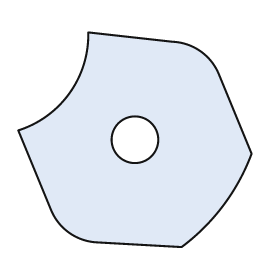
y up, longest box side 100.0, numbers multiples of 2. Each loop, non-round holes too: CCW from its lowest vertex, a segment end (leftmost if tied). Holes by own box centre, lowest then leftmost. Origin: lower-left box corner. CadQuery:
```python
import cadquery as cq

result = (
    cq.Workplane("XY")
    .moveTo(70.0, 0.0)
    .threePointArc((88.0, 18.0), (100.0, 40.0))
    .lineTo(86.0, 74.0)
    .threePointArc((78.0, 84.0), (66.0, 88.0))
    .lineTo(30.0, 92.0)
    .threePointArc((22.0, 66.0), (0.0, 50.0))
    .lineTo(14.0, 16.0)
    .threePointArc((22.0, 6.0), (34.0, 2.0))
    .close()
    .moveTo(50.0, 46.0)
    .circle(10.0)
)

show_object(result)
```